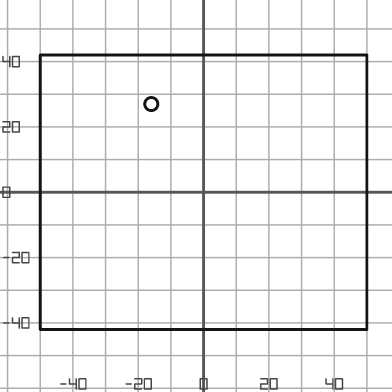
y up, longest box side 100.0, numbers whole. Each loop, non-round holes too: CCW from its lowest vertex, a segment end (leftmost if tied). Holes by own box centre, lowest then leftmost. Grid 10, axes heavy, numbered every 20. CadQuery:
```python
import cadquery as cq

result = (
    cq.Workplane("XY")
    .moveTo(-50.0, -42.0)
    .lineTo(50.0, -42.0)
    .lineTo(50.0, 42.0)
    .lineTo(-50.0, 42.0)
    .close()
    .moveTo(-16.0, 27.0)
    .circle(2.0)
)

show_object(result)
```